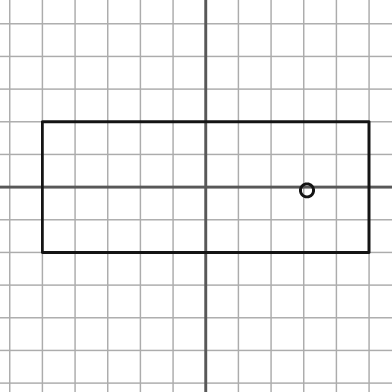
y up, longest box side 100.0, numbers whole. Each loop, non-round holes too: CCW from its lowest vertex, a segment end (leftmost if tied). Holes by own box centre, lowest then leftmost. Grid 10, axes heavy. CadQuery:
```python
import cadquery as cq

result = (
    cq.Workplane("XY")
    .moveTo(-50.0, -20.0)
    .lineTo(50.0, -20.0)
    .lineTo(50.0, 20.0)
    .lineTo(-50.0, 20.0)
    .close()
    .moveTo(31.0, -1.0)
    .circle(2.0)
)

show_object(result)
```